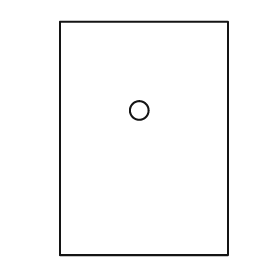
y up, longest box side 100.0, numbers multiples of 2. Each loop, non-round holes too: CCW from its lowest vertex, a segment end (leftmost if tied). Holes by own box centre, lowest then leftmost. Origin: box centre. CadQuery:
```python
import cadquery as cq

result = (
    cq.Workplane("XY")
    .moveTo(-36.0, -50.0)
    .lineTo(36.0, -50.0)
    .lineTo(36.0, 50.0)
    .lineTo(-36.0, 50.0)
    .close()
    .moveTo(-2.0, 12.0)
    .circle(4.0)
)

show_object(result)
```